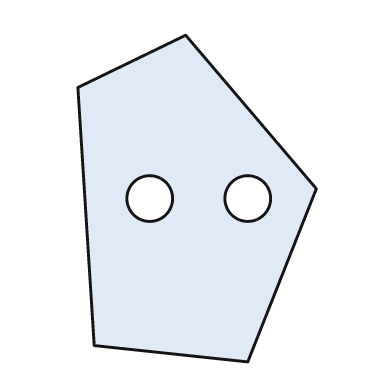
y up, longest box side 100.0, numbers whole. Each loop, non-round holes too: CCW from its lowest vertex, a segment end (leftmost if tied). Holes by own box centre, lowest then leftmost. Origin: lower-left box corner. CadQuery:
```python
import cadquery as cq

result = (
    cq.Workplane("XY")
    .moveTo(52.0, 0.0)
    .lineTo(73.0, 53.0)
    .lineTo(33.0, 100.0)
    .lineTo(0.0, 84.0)
    .lineTo(5.0, 5.0)
    .close()
    .moveTo(22.0, 50.0)
    .circle(7.0)
    .moveTo(52.0, 50.0)
    .circle(7.0)
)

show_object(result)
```